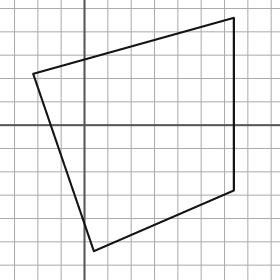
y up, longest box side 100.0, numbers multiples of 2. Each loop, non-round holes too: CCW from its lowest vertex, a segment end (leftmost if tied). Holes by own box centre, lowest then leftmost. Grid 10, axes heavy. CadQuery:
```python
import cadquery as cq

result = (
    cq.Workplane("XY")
    .moveTo(4.0, -54.0)
    .lineTo(64.0, -28.0)
    .lineTo(64.0, 46.0)
    .lineTo(-22.0, 22.0)
    .close()
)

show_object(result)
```